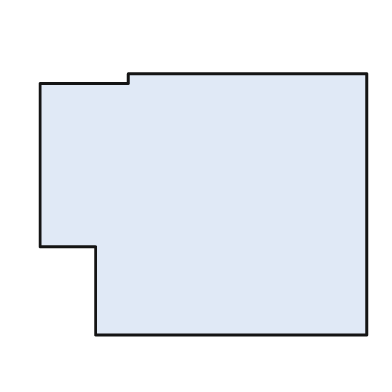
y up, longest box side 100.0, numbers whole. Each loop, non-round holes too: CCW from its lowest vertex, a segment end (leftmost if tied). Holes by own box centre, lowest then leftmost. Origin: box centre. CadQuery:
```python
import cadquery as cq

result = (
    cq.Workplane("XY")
    .moveTo(-33.0, -40.0)
    .lineTo(50.0, -40.0)
    .lineTo(50.0, 40.0)
    .lineTo(-23.0, 40.0)
    .lineTo(-23.0, 37.0)
    .lineTo(-50.0, 37.0)
    .lineTo(-50.0, -13.0)
    .lineTo(-33.0, -13.0)
    .close()
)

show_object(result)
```